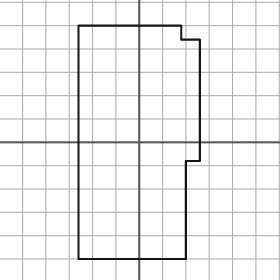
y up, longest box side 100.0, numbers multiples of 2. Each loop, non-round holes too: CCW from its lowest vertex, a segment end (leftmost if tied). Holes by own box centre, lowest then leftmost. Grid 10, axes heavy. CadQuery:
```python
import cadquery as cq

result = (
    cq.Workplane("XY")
    .moveTo(-26.0, -50.0)
    .lineTo(20.0, -50.0)
    .lineTo(20.0, -8.0)
    .lineTo(26.0, -8.0)
    .lineTo(26.0, 44.0)
    .lineTo(18.0, 44.0)
    .lineTo(18.0, 50.0)
    .lineTo(-26.0, 50.0)
    .close()
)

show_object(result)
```